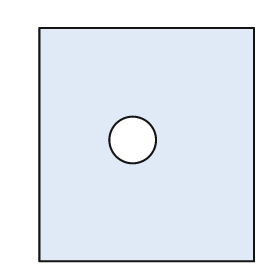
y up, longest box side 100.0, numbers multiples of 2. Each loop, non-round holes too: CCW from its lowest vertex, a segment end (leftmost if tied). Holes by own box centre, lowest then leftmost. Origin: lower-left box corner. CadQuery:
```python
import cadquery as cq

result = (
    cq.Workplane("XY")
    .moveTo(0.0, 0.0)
    .lineTo(92.0, 0.0)
    .lineTo(92.0, 100.0)
    .lineTo(0.0, 100.0)
    .close()
    .moveTo(40.0, 52.0)
    .circle(10.0)
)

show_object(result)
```